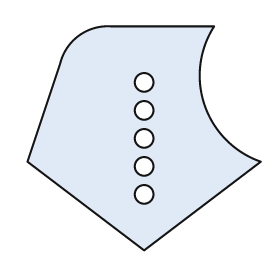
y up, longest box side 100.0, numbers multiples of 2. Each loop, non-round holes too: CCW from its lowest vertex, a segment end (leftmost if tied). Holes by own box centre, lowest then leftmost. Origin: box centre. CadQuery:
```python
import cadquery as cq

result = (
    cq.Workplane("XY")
    .moveTo(0.0, -48.0)
    .lineTo(50.0, -10.0)
    .threePointArc((26.0, 14.0), (30.0, 48.0))
    .lineTo(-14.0, 48.0)
    .threePointArc((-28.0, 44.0), (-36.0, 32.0))
    .lineTo(-50.0, -10.0)
    .close()
    .moveTo(0.0, -24.0)
    .circle(4.0)
    .moveTo(0.0, -12.0)
    .circle(4.0)
    .moveTo(0.0, 0.0)
    .circle(4.0)
    .moveTo(0.0, 12.0)
    .circle(4.0)
    .moveTo(0.0, 24.0)
    .circle(4.0)
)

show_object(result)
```